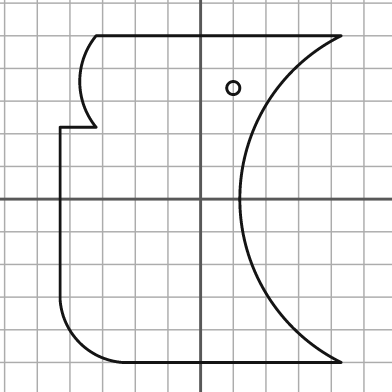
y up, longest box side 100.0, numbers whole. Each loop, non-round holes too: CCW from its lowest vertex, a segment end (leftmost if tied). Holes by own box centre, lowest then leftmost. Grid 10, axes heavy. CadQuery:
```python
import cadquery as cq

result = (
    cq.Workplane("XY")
    .moveTo(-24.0, -50.0)
    .lineTo(43.0, -50.0)
    .threePointArc((12.0, 0.0), (43.0, 50.0))
    .lineTo(-32.0, 50.0)
    .threePointArc((-37.0, 36.0), (-32.0, 22.0))
    .lineTo(-43.0, 22.0)
    .lineTo(-43.0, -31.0)
    .threePointArc((-37.0, -44.0), (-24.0, -50.0))
    .close()
    .moveTo(10.0, 34.0)
    .circle(2.0)
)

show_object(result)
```